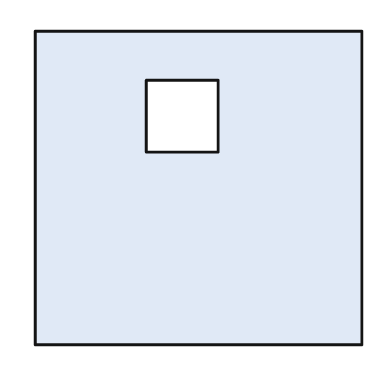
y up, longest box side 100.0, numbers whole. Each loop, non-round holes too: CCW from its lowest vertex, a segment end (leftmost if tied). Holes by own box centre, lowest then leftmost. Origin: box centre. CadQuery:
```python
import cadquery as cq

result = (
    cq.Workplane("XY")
    .moveTo(-50.0, -48.0)
    .lineTo(50.0, -48.0)
    .lineTo(50.0, 48.0)
    .lineTo(-50.0, 48.0)
    .close()
    .moveTo(-16.0, 11.0)
    .lineTo(6.0, 11.0)
    .lineTo(6.0, 33.0)
    .lineTo(-16.0, 33.0)
    .close()
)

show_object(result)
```